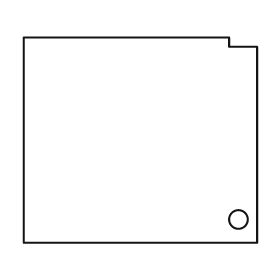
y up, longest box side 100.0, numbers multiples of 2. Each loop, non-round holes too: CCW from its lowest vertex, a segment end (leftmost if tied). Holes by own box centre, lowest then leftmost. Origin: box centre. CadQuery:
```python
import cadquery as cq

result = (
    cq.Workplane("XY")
    .moveTo(-50.0, -44.0)
    .lineTo(50.0, -44.0)
    .lineTo(50.0, 40.0)
    .lineTo(38.0, 40.0)
    .lineTo(38.0, 44.0)
    .lineTo(-50.0, 44.0)
    .close()
    .moveTo(42.0, -34.0)
    .circle(4.0)
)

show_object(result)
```